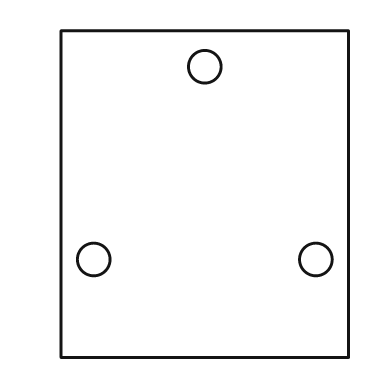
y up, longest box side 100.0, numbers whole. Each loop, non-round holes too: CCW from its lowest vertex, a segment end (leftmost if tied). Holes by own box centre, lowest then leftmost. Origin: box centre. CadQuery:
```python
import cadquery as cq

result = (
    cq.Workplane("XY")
    .moveTo(-44.0, -50.0)
    .lineTo(44.0, -50.0)
    .lineTo(44.0, 50.0)
    .lineTo(-44.0, 50.0)
    .close()
    .moveTo(-34.0, -20.0)
    .circle(5.0)
    .moveTo(34.0, -20.0)
    .circle(5.0)
    .moveTo(0.0, 39.0)
    .circle(5.0)
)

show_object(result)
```